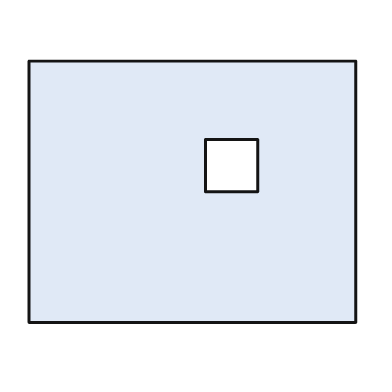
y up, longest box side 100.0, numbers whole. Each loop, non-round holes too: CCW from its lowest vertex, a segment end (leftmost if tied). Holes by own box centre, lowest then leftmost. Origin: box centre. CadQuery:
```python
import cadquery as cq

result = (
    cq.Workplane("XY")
    .moveTo(-50.0, -40.0)
    .lineTo(50.0, -40.0)
    .lineTo(50.0, 40.0)
    .lineTo(-50.0, 40.0)
    .close()
    .moveTo(4.0, 0.0)
    .lineTo(20.0, 0.0)
    .lineTo(20.0, 16.0)
    .lineTo(4.0, 16.0)
    .close()
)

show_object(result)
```